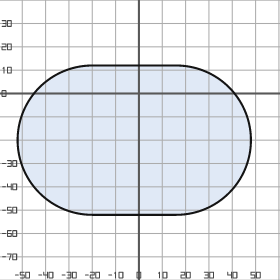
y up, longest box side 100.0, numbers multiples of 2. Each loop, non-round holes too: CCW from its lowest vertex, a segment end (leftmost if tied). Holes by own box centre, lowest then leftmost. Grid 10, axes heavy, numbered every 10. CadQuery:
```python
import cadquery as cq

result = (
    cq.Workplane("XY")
    .moveTo(-20.0, -52.0)
    .lineTo(16.0, -52.0)
    .threePointArc((48.0, -20.0), (16.0, 12.0))
    .lineTo(-20.0, 12.0)
    .threePointArc((-52.0, -20.0), (-20.0, -52.0))
    .close()
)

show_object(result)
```